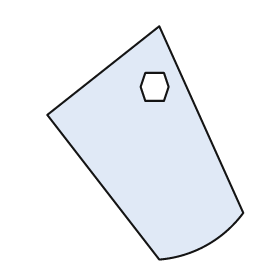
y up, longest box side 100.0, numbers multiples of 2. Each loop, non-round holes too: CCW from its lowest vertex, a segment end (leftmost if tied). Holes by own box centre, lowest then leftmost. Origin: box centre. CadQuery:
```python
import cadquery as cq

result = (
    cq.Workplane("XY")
    .moveTo(6.0, -50.0)
    .threePointArc((26.0, -44.0), (42.0, -30.0))
    .lineTo(6.0, 50.0)
    .lineTo(-42.0, 12.0)
    .close()
    .moveTo(0.0, 18.0)
    .lineTo(8.0, 18.0)
    .lineTo(10.0, 24.0)
    .lineTo(8.0, 30.0)
    .lineTo(0.0, 30.0)
    .lineTo(-2.0, 24.0)
    .close()
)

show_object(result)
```